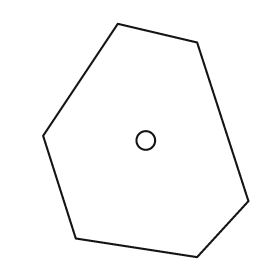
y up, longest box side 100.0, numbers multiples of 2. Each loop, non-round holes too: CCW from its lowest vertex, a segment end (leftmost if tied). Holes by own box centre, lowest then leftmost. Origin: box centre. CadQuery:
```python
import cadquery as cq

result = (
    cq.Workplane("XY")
    .moveTo(22.0, -50.0)
    .lineTo(44.0, -26.0)
    .lineTo(22.0, 42.0)
    .lineTo(-12.0, 50.0)
    .lineTo(-44.0, 2.0)
    .lineTo(-30.0, -42.0)
    .close()
    .moveTo(0.0, 0.0)
    .circle(4.0)
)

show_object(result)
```